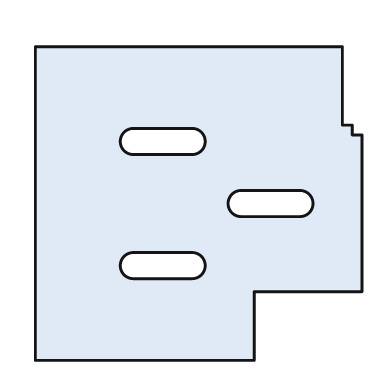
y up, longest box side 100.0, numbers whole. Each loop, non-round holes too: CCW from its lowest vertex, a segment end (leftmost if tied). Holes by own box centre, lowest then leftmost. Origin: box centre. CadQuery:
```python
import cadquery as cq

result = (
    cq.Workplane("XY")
    .moveTo(-50.0, -48.0)
    .lineTo(17.0, -48.0)
    .lineTo(17.0, -27.0)
    .lineTo(50.0, -27.0)
    .lineTo(50.0, 21.0)
    .lineTo(47.0, 21.0)
    .lineTo(47.0, 24.0)
    .lineTo(44.0, 24.0)
    .lineTo(44.0, 48.0)
    .lineTo(-50.0, 48.0)
    .close()
    .moveTo(-20.0, -23.0)
    .lineTo(-2.0, -23.0)
    .threePointArc((2.0, -19.0), (-2.0, -15.0))
    .lineTo(-20.0, -15.0)
    .threePointArc((-24.0, -19.0), (-20.0, -23.0))
    .close()
    .moveTo(13.0, -4.0)
    .lineTo(31.0, -4.0)
    .threePointArc((35.0, 0.0), (31.0, 4.0))
    .lineTo(13.0, 4.0)
    .threePointArc((9.0, 0.0), (13.0, -4.0))
    .close()
    .moveTo(-20.0, 15.0)
    .lineTo(-2.0, 15.0)
    .threePointArc((2.0, 19.0), (-2.0, 23.0))
    .lineTo(-20.0, 23.0)
    .threePointArc((-24.0, 19.0), (-20.0, 15.0))
    .close()
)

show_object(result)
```